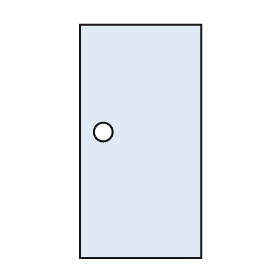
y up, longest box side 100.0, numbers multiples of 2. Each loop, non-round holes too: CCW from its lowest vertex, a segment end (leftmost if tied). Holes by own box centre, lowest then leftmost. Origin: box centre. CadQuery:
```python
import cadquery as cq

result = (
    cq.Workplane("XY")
    .moveTo(-26.0, -50.0)
    .lineTo(26.0, -50.0)
    .lineTo(26.0, 50.0)
    .lineTo(-26.0, 50.0)
    .close()
    .moveTo(-16.0, 4.0)
    .circle(4.0)
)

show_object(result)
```